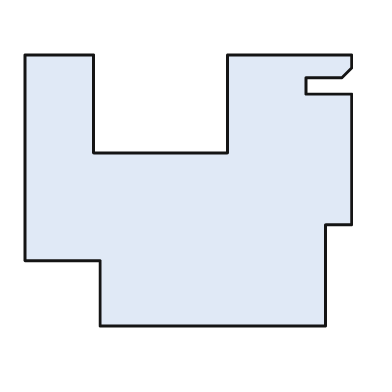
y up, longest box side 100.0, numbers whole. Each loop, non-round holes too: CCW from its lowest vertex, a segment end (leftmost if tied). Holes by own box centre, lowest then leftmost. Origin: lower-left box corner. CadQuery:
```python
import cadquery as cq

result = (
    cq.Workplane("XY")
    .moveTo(23.0, 0.0)
    .lineTo(92.0, 0.0)
    .lineTo(92.0, 31.0)
    .lineTo(100.0, 31.0)
    .lineTo(100.0, 71.0)
    .lineTo(86.0, 71.0)
    .lineTo(86.0, 76.0)
    .lineTo(97.0, 76.0)
    .lineTo(100.0, 79.0)
    .lineTo(100.0, 83.0)
    .lineTo(62.0, 83.0)
    .lineTo(62.0, 53.0)
    .lineTo(21.0, 53.0)
    .lineTo(21.0, 83.0)
    .lineTo(0.0, 83.0)
    .lineTo(0.0, 20.0)
    .lineTo(23.0, 20.0)
    .close()
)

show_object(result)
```